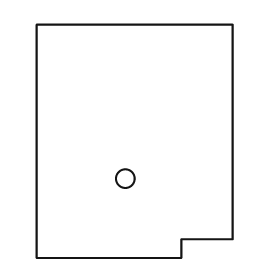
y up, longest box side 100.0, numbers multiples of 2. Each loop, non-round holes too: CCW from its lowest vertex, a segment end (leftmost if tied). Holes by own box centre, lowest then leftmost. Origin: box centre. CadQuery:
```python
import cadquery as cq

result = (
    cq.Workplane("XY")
    .moveTo(-42.0, -50.0)
    .lineTo(20.0, -50.0)
    .lineTo(20.0, -42.0)
    .lineTo(42.0, -42.0)
    .lineTo(42.0, 50.0)
    .lineTo(-42.0, 50.0)
    .close()
    .moveTo(-4.0, -16.0)
    .circle(4.0)
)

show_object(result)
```